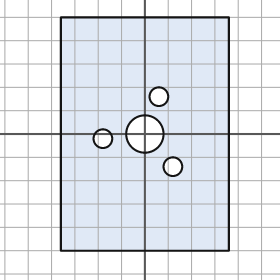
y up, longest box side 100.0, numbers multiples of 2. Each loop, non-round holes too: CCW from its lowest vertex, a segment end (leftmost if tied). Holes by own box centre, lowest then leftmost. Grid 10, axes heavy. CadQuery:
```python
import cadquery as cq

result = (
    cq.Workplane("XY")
    .moveTo(-36.0, -50.0)
    .lineTo(36.0, -50.0)
    .lineTo(36.0, 50.0)
    .lineTo(-36.0, 50.0)
    .close()
    .moveTo(12.0, -14.0)
    .circle(4.0)
    .moveTo(-18.0, -2.0)
    .circle(4.0)
    .moveTo(0.0, 0.0)
    .circle(8.0)
    .moveTo(6.0, 16.0)
    .circle(4.0)
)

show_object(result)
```